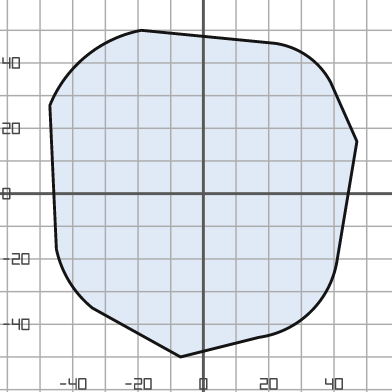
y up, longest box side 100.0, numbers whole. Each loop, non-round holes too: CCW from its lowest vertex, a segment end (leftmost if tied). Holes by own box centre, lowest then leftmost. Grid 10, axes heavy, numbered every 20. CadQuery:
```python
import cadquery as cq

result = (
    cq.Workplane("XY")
    .moveTo(-7.0, -50.0)
    .lineTo(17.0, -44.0)
    .threePointArc((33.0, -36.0), (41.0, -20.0))
    .lineTo(47.0, 16.0)
    .lineTo(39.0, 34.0)
    .threePointArc((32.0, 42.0), (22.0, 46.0))
    .lineTo(-19.0, 50.0)
    .threePointArc((-36.0, 42.0), (-47.0, 27.0))
    .lineTo(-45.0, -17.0)
    .threePointArc((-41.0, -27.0), (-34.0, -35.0))
    .close()
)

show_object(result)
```